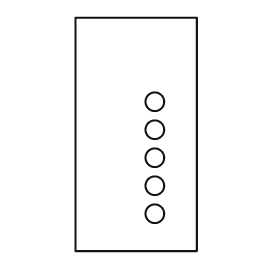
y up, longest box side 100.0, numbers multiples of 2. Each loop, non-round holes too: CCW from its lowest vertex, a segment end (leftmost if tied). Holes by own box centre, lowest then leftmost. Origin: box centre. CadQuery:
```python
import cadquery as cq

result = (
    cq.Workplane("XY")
    .moveTo(-26.0, -50.0)
    .lineTo(26.0, -50.0)
    .lineTo(26.0, 50.0)
    .lineTo(-26.0, 50.0)
    .close()
    .moveTo(8.0, -34.0)
    .circle(4.0)
    .moveTo(8.0, -22.0)
    .circle(4.0)
    .moveTo(8.0, -10.0)
    .circle(4.0)
    .moveTo(8.0, 2.0)
    .circle(4.0)
    .moveTo(8.0, 14.0)
    .circle(4.0)
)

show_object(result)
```